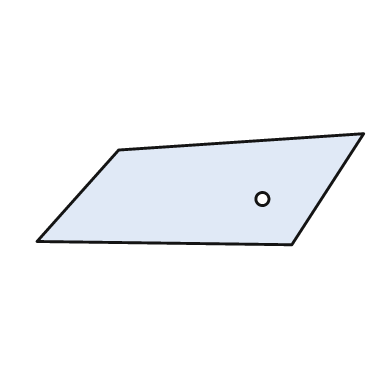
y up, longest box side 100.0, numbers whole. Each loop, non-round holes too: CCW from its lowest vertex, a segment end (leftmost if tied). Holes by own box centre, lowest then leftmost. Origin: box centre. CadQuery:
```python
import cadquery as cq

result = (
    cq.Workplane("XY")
    .moveTo(28.0, -17.0)
    .lineTo(50.0, 17.0)
    .lineTo(-25.0, 12.0)
    .lineTo(-50.0, -16.0)
    .close()
    .moveTo(19.0, -3.0)
    .circle(2.0)
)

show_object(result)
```